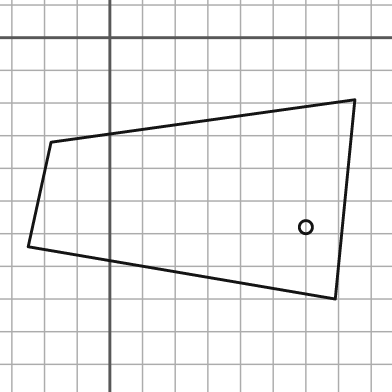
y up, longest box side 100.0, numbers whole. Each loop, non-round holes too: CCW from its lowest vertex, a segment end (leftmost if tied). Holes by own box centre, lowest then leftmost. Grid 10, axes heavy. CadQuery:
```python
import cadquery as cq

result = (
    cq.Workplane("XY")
    .moveTo(69.0, -80.0)
    .lineTo(75.0, -19.0)
    .lineTo(-18.0, -32.0)
    .lineTo(-25.0, -64.0)
    .close()
    .moveTo(60.0, -58.0)
    .circle(2.0)
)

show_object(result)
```